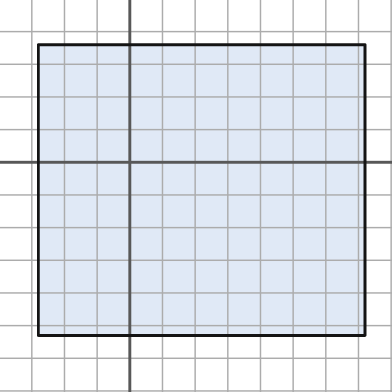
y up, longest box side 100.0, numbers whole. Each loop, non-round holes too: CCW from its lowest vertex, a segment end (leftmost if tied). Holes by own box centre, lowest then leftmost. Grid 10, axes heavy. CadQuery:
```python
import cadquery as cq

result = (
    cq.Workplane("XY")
    .moveTo(-28.0, -53.0)
    .lineTo(72.0, -53.0)
    .lineTo(72.0, 36.0)
    .lineTo(-28.0, 36.0)
    .close()
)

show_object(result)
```